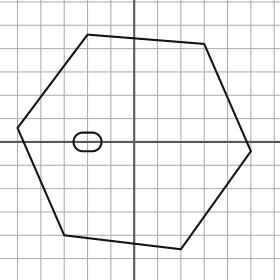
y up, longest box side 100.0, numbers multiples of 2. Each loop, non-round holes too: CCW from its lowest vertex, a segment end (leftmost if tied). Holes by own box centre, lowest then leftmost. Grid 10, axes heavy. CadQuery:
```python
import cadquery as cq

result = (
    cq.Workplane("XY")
    .moveTo(20.0, -46.0)
    .lineTo(50.0, -4.0)
    .lineTo(30.0, 42.0)
    .lineTo(-20.0, 46.0)
    .lineTo(-50.0, 6.0)
    .lineTo(-30.0, -40.0)
    .close()
    .moveTo(-22.0, -4.0)
    .lineTo(-18.0, -4.0)
    .threePointArc((-14.0, 0.0), (-18.0, 4.0))
    .lineTo(-22.0, 4.0)
    .threePointArc((-26.0, 0.0), (-22.0, -4.0))
    .close()
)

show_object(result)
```